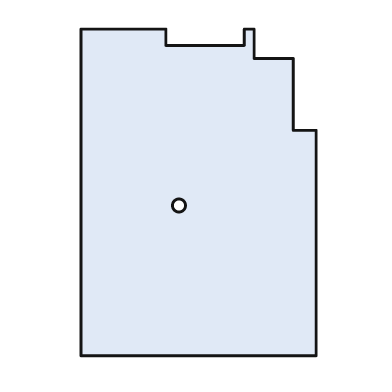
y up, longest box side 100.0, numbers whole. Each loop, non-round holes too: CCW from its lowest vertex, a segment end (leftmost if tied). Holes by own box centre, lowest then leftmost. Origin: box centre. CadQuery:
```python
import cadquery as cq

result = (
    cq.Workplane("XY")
    .moveTo(-36.0, -50.0)
    .lineTo(36.0, -50.0)
    .lineTo(36.0, 19.0)
    .lineTo(29.0, 19.0)
    .lineTo(29.0, 41.0)
    .lineTo(17.0, 41.0)
    .lineTo(17.0, 50.0)
    .lineTo(14.0, 50.0)
    .lineTo(14.0, 45.0)
    .lineTo(-10.0, 45.0)
    .lineTo(-10.0, 50.0)
    .lineTo(-36.0, 50.0)
    .close()
    .moveTo(-6.0, -4.0)
    .circle(2.0)
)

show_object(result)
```